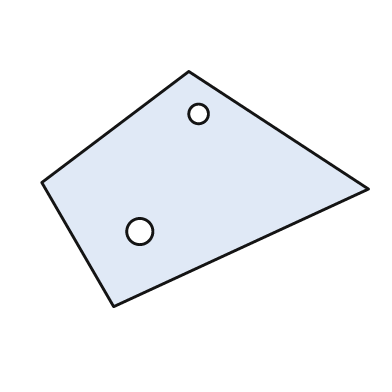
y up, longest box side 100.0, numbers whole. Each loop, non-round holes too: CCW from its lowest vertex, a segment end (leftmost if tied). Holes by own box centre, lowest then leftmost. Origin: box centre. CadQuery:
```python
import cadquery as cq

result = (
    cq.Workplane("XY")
    .moveTo(-28.0, -36.0)
    .lineTo(50.0, 0.0)
    .lineTo(-5.0, 36.0)
    .lineTo(-50.0, 2.0)
    .close()
    .moveTo(-20.0, -13.0)
    .circle(4.0)
    .moveTo(-2.0, 23.0)
    .circle(3.0)
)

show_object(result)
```